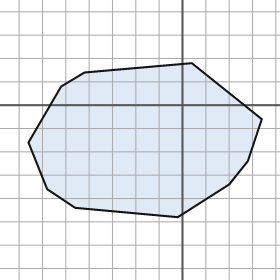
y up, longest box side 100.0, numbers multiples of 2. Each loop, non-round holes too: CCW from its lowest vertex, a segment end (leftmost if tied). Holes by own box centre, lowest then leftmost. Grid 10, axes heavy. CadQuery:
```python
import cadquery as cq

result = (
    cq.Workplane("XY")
    .moveTo(-2.0, -48.0)
    .lineTo(20.0, -34.0)
    .lineTo(28.0, -24.0)
    .lineTo(34.0, -6.0)
    .lineTo(4.0, 18.0)
    .lineTo(-42.0, 14.0)
    .lineTo(-52.0, 8.0)
    .lineTo(-66.0, -16.0)
    .lineTo(-58.0, -36.0)
    .lineTo(-46.0, -44.0)
    .close()
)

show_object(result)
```